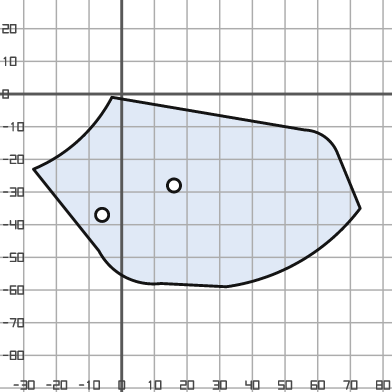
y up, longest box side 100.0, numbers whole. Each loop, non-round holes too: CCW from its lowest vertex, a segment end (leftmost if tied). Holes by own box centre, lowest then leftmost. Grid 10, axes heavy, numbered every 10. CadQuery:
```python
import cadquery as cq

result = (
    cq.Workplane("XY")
    .moveTo(32.0, -59.0)
    .threePointArc((55.0, -51.0), (73.0, -35.0))
    .lineTo(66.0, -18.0)
    .threePointArc((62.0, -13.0), (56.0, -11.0))
    .lineTo(-3.0, -1.0)
    .threePointArc((-13.0, -14.0), (-27.0, -23.0))
    .lineTo(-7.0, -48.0)
    .threePointArc((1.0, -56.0), (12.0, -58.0))
    .close()
    .moveTo(-6.0, -37.0)
    .circle(2.0)
    .moveTo(16.0, -28.0)
    .circle(2.0)
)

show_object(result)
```